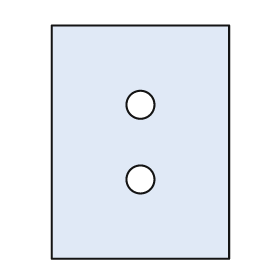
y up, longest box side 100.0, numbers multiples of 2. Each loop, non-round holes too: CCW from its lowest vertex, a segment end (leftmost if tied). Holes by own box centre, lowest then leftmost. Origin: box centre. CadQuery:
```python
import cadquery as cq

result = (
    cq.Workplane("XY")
    .moveTo(-38.0, -50.0)
    .lineTo(38.0, -50.0)
    .lineTo(38.0, 50.0)
    .lineTo(-38.0, 50.0)
    .close()
    .moveTo(0.0, -16.0)
    .circle(6.0)
    .moveTo(0.0, 16.0)
    .circle(6.0)
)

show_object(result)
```